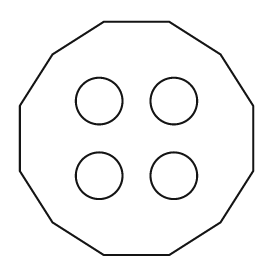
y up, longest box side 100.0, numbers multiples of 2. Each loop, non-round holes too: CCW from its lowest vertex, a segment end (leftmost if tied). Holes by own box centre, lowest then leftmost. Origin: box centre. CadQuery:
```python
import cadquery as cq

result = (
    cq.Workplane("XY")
    .moveTo(-14.0, -50.0)
    .lineTo(14.0, -50.0)
    .lineTo(36.0, -36.0)
    .lineTo(50.0, -14.0)
    .lineTo(50.0, 14.0)
    .lineTo(36.0, 36.0)
    .lineTo(14.0, 50.0)
    .lineTo(-14.0, 50.0)
    .lineTo(-36.0, 36.0)
    .lineTo(-50.0, 14.0)
    .lineTo(-50.0, -14.0)
    .lineTo(-36.0, -36.0)
    .close()
    .moveTo(-16.0, -16.0)
    .circle(10.0)
    .moveTo(16.0, -16.0)
    .circle(10.0)
    .moveTo(-16.0, 16.0)
    .circle(10.0)
    .moveTo(16.0, 16.0)
    .circle(10.0)
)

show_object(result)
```